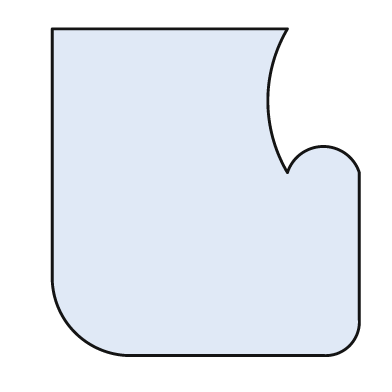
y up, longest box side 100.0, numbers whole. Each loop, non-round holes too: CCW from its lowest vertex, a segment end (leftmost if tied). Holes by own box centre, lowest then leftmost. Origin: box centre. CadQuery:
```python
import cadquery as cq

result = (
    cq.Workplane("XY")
    .moveTo(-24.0, -50.0)
    .lineTo(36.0, -50.0)
    .threePointArc((44.0, -47.0), (47.0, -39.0))
    .lineTo(47.0, 6.0)
    .threePointArc((36.0, 14.0), (25.0, 6.0))
    .threePointArc((19.0, 28.0), (25.0, 50.0))
    .lineTo(-47.0, 50.0)
    .lineTo(-47.0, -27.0)
    .threePointArc((-40.0, -43.0), (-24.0, -50.0))
    .close()
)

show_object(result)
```